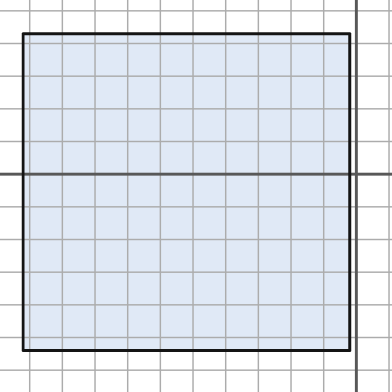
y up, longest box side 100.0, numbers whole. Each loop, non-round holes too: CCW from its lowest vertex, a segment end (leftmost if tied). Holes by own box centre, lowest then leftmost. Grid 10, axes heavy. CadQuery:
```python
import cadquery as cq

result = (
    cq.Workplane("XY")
    .moveTo(-102.0, -54.0)
    .lineTo(-2.0, -54.0)
    .lineTo(-2.0, 43.0)
    .lineTo(-102.0, 43.0)
    .close()
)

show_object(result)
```